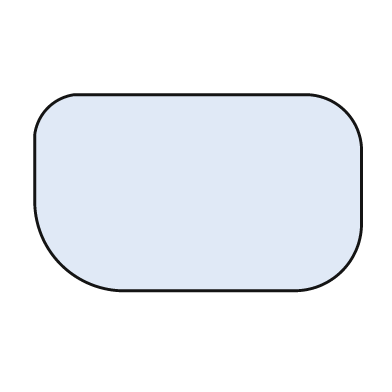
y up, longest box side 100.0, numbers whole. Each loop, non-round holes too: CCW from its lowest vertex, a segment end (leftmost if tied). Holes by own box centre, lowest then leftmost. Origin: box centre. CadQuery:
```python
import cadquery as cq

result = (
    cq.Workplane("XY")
    .moveTo(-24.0, -30.0)
    .lineTo(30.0, -30.0)
    .threePointArc((44.0, -24.0), (50.0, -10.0))
    .lineTo(50.0, 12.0)
    .threePointArc((45.0, 25.0), (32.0, 30.0))
    .lineTo(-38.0, 30.0)
    .threePointArc((-46.0, 26.0), (-50.0, 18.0))
    .lineTo(-50.0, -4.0)
    .threePointArc((-42.0, -22.0), (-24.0, -30.0))
    .close()
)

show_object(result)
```